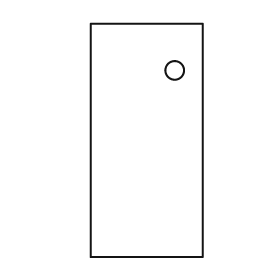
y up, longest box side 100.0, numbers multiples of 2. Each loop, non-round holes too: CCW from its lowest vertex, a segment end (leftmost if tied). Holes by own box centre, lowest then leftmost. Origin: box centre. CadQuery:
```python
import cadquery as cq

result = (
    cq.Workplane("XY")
    .moveTo(-24.0, -50.0)
    .lineTo(24.0, -50.0)
    .lineTo(24.0, 50.0)
    .lineTo(-24.0, 50.0)
    .close()
    .moveTo(12.0, 30.0)
    .circle(4.0)
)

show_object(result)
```